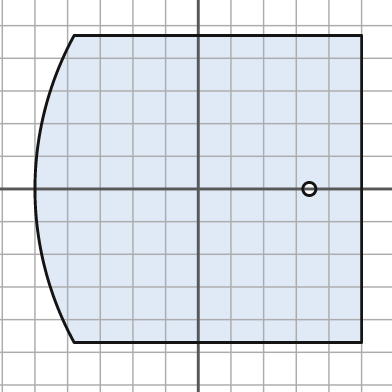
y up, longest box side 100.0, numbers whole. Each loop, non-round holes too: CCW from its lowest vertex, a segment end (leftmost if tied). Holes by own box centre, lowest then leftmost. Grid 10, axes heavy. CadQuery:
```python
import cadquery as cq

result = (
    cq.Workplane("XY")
    .moveTo(-38.0, -47.0)
    .lineTo(50.0, -47.0)
    .lineTo(50.0, 47.0)
    .lineTo(-38.0, 47.0)
    .threePointArc((-50.0, 0.0), (-38.0, -47.0))
    .close()
    .moveTo(34.0, 0.0)
    .circle(2.0)
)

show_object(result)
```